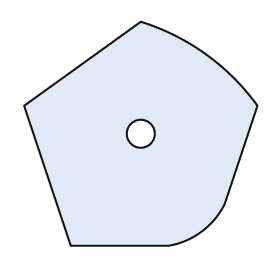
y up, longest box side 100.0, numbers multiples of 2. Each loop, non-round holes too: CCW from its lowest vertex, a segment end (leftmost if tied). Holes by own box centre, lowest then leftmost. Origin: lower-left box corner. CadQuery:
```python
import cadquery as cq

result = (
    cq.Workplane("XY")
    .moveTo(20.0, 0.0)
    .lineTo(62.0, 0.0)
    .threePointArc((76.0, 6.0), (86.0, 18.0))
    .lineTo(100.0, 60.0)
    .threePointArc((78.0, 82.0), (50.0, 96.0))
    .lineTo(0.0, 60.0)
    .close()
    .moveTo(50.0, 48.0)
    .circle(6.0)
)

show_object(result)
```